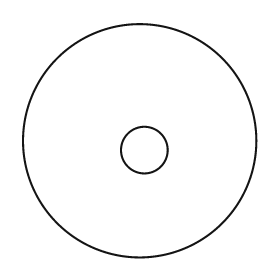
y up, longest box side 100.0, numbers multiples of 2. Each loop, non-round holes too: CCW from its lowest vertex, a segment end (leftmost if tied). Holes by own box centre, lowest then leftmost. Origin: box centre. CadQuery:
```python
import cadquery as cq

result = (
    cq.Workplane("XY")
    .moveTo(0.0, 0.0)
    .circle(50.0)
    .moveTo(2.0, -4.0)
    .circle(10.0)
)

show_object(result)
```